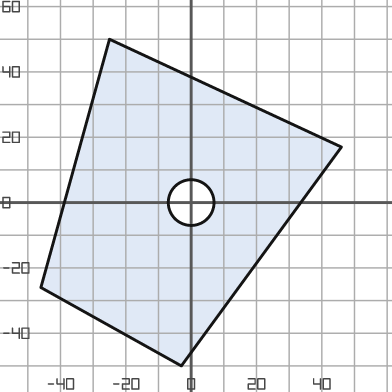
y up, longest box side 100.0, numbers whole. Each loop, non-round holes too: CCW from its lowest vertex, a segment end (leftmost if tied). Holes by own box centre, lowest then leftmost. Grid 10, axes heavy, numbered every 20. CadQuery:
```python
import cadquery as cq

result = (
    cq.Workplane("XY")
    .moveTo(-3.0, -50.0)
    .lineTo(46.0, 17.0)
    .lineTo(-25.0, 50.0)
    .lineTo(-46.0, -26.0)
    .close()
    .moveTo(0.0, 0.0)
    .circle(7.0)
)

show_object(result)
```